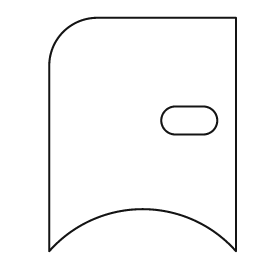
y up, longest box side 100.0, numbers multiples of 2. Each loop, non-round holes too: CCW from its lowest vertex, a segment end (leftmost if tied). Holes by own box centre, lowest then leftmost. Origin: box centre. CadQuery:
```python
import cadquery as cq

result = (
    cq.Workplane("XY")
    .moveTo(-40.0, -50.0)
    .threePointArc((0.0, -32.0), (40.0, -50.0))
    .lineTo(40.0, 50.0)
    .lineTo(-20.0, 50.0)
    .threePointArc((-34.0, 44.0), (-40.0, 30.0))
    .close()
    .moveTo(14.0, 0.0)
    .lineTo(26.0, 0.0)
    .threePointArc((32.0, 6.0), (26.0, 12.0))
    .lineTo(14.0, 12.0)
    .threePointArc((8.0, 6.0), (14.0, 0.0))
    .close()
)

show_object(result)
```